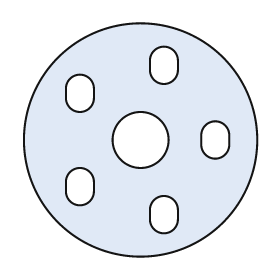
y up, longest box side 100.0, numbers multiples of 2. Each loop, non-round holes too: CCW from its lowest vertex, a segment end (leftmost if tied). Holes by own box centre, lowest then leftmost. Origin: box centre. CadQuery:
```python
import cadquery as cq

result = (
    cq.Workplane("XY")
    .moveTo(0.0, 0.0)
    .circle(50.0)
    .moveTo(4.0, -34.0)
    .threePointArc((10.0, -40.0), (16.0, -34.0))
    .lineTo(16.0, -30.0)
    .threePointArc((10.0, -24.0), (4.0, -30.0))
    .close()
    .moveTo(-32.0, -22.0)
    .threePointArc((-26.0, -28.0), (-20.0, -22.0))
    .lineTo(-20.0, -18.0)
    .threePointArc((-26.0, -12.0), (-32.0, -18.0))
    .close()
    .moveTo(0.0, 0.0)
    .circle(12.0)
    .moveTo(26.0, -2.0)
    .threePointArc((32.0, -8.0), (38.0, -2.0))
    .lineTo(38.0, 2.0)
    .threePointArc((32.0, 8.0), (26.0, 2.0))
    .close()
    .moveTo(-32.0, 18.0)
    .threePointArc((-26.0, 12.0), (-20.0, 18.0))
    .lineTo(-20.0, 22.0)
    .threePointArc((-26.0, 28.0), (-32.0, 22.0))
    .close()
    .moveTo(4.0, 30.0)
    .threePointArc((10.0, 24.0), (16.0, 30.0))
    .lineTo(16.0, 34.0)
    .threePointArc((10.0, 40.0), (4.0, 34.0))
    .close()
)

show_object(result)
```